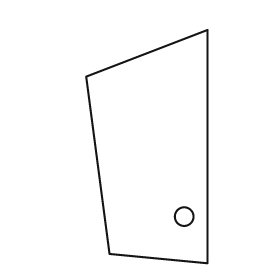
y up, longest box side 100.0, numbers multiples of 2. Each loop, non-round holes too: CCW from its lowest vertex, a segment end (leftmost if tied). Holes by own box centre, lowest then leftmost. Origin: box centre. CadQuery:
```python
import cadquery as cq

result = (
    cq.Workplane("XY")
    .moveTo(26.0, -50.0)
    .lineTo(26.0, 50.0)
    .lineTo(-26.0, 30.0)
    .lineTo(-16.0, -46.0)
    .close()
    .moveTo(16.0, -30.0)
    .circle(4.0)
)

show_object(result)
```